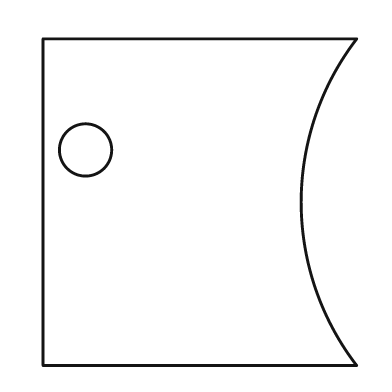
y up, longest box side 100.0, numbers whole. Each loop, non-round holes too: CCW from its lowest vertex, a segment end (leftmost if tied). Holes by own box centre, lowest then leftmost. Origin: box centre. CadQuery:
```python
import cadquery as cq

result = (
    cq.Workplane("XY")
    .moveTo(-48.0, -50.0)
    .lineTo(48.0, -50.0)
    .threePointArc((31.0, 0.0), (48.0, 50.0))
    .lineTo(-48.0, 50.0)
    .close()
    .moveTo(-35.0, 16.0)
    .circle(8.0)
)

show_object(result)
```